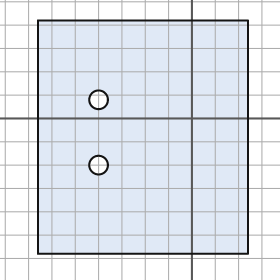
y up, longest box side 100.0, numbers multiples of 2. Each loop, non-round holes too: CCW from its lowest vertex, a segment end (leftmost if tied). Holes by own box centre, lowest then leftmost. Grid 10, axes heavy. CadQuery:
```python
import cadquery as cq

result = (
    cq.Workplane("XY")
    .moveTo(-66.0, -58.0)
    .lineTo(24.0, -58.0)
    .lineTo(24.0, 42.0)
    .lineTo(-66.0, 42.0)
    .close()
    .moveTo(-40.0, -20.0)
    .circle(4.0)
    .moveTo(-40.0, 8.0)
    .circle(4.0)
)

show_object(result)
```